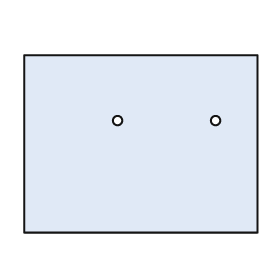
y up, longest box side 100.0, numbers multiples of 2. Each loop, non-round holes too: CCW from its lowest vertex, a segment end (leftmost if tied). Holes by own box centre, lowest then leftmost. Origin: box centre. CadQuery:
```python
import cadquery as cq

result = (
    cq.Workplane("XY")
    .moveTo(-50.0, -38.0)
    .lineTo(50.0, -38.0)
    .lineTo(50.0, 38.0)
    .lineTo(-50.0, 38.0)
    .close()
    .moveTo(-10.0, 10.0)
    .circle(2.0)
    .moveTo(32.0, 10.0)
    .circle(2.0)
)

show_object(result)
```